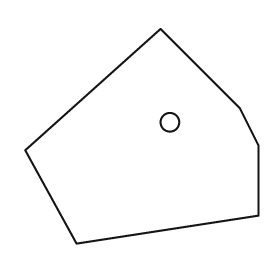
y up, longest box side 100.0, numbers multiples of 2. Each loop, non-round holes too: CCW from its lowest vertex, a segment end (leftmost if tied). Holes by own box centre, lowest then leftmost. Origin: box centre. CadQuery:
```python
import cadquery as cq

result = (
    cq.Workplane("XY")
    .moveTo(-28.0, -46.0)
    .lineTo(50.0, -34.0)
    .lineTo(50.0, -4.0)
    .lineTo(42.0, 12.0)
    .lineTo(8.0, 46.0)
    .lineTo(-50.0, -6.0)
    .close()
    .moveTo(12.0, 6.0)
    .circle(4.0)
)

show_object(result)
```